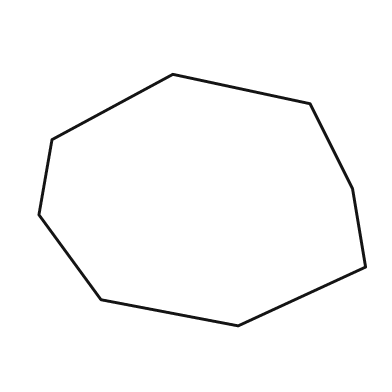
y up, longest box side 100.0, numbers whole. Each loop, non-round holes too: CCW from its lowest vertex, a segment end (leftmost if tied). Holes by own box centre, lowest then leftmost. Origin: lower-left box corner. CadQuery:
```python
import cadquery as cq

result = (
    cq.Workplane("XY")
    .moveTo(61.0, 0.0)
    .lineTo(100.0, 18.0)
    .lineTo(96.0, 42.0)
    .lineTo(83.0, 68.0)
    .lineTo(41.0, 77.0)
    .lineTo(4.0, 57.0)
    .lineTo(0.0, 34.0)
    .lineTo(19.0, 8.0)
    .close()
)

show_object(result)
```